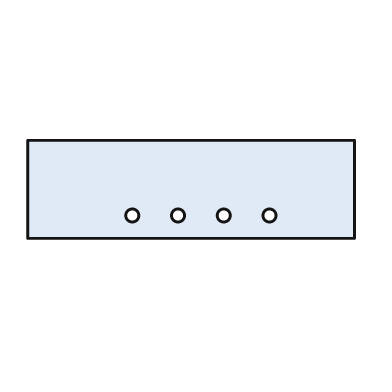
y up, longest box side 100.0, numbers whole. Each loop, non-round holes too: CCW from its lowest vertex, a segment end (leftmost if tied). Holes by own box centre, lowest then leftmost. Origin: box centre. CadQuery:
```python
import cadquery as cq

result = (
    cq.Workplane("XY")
    .moveTo(-50.0, -15.0)
    .lineTo(50.0, -15.0)
    .lineTo(50.0, 15.0)
    .lineTo(-50.0, 15.0)
    .close()
    .moveTo(-18.0, -8.0)
    .circle(2.0)
    .moveTo(-4.0, -8.0)
    .circle(2.0)
    .moveTo(10.0, -8.0)
    .circle(2.0)
    .moveTo(24.0, -8.0)
    .circle(2.0)
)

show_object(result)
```